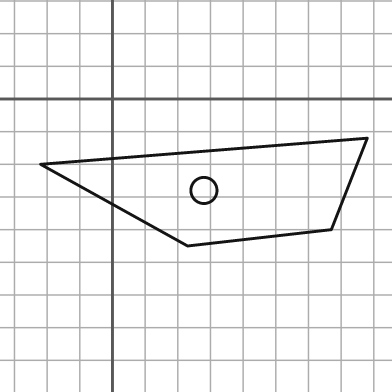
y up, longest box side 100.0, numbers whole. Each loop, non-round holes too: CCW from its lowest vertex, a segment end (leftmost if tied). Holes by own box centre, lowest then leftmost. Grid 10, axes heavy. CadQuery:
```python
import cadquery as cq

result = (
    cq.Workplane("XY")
    .moveTo(23.0, -45.0)
    .lineTo(67.0, -40.0)
    .lineTo(78.0, -12.0)
    .lineTo(-22.0, -20.0)
    .close()
    .moveTo(28.0, -28.0)
    .circle(4.0)
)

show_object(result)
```